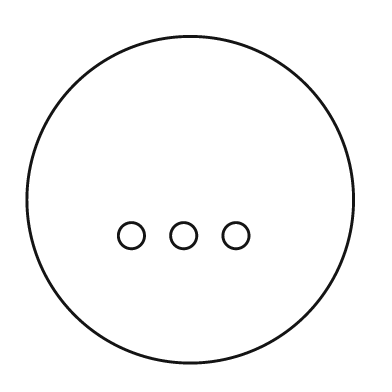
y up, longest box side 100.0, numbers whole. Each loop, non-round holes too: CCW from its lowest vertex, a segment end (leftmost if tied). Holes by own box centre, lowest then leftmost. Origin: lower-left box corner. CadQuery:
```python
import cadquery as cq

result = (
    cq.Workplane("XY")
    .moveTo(50.0, 50.0)
    .circle(50.0)
    .moveTo(32.0, 39.0)
    .circle(4.0)
    .moveTo(48.0, 39.0)
    .circle(4.0)
    .moveTo(64.0, 39.0)
    .circle(4.0)
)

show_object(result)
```